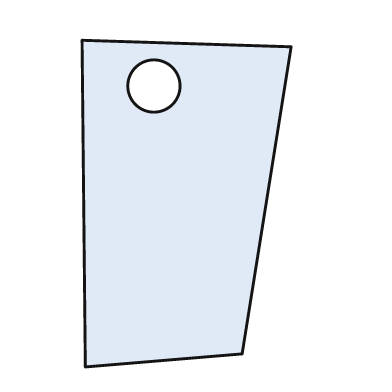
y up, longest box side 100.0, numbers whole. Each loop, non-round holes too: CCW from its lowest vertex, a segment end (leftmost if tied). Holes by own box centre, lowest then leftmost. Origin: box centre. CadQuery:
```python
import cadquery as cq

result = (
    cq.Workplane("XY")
    .moveTo(-31.0, -50.0)
    .lineTo(17.0, -46.0)
    .lineTo(32.0, 48.0)
    .lineTo(-32.0, 50.0)
    .close()
    .moveTo(-10.0, 36.0)
    .circle(8.0)
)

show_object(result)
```